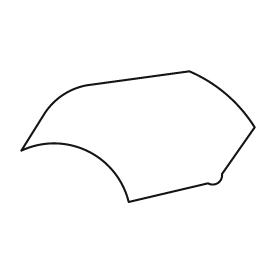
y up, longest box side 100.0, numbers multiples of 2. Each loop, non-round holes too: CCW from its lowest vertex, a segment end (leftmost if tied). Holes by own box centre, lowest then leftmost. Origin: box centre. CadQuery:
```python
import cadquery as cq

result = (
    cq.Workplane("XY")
    .moveTo(-4.0, -28.0)
    .lineTo(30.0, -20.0)
    .threePointArc((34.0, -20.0), (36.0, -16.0))
    .lineTo(50.0, 4.0)
    .threePointArc((38.0, 18.0), (22.0, 28.0))
    .lineTo(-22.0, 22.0)
    .threePointArc((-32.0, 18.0), (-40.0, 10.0))
    .lineTo(-50.0, -6.0)
    .threePointArc((-22.0, -6.0), (-4.0, -28.0))
    .close()
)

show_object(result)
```